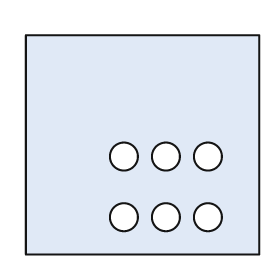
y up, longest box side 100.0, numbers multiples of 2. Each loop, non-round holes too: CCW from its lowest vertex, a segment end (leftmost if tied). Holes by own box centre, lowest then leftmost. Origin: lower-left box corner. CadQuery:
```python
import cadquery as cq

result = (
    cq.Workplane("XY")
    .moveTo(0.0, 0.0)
    .lineTo(100.0, 0.0)
    .lineTo(100.0, 94.0)
    .lineTo(0.0, 94.0)
    .close()
    .moveTo(42.0, 16.0)
    .circle(6.0)
    .moveTo(60.0, 16.0)
    .circle(6.0)
    .moveTo(78.0, 16.0)
    .circle(6.0)
    .moveTo(42.0, 42.0)
    .circle(6.0)
    .moveTo(60.0, 42.0)
    .circle(6.0)
    .moveTo(78.0, 42.0)
    .circle(6.0)
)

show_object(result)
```